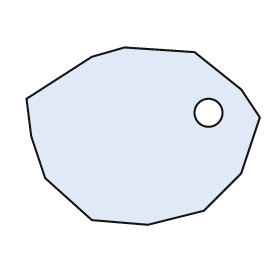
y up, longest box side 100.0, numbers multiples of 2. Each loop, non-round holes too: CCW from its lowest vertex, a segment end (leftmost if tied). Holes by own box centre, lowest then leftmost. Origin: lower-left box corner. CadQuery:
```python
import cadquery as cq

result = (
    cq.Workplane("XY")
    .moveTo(52.0, 0.0)
    .lineTo(76.0, 6.0)
    .lineTo(92.0, 22.0)
    .lineTo(100.0, 46.0)
    .lineTo(92.0, 58.0)
    .lineTo(72.0, 74.0)
    .lineTo(42.0, 76.0)
    .lineTo(28.0, 72.0)
    .lineTo(0.0, 54.0)
    .lineTo(2.0, 38.0)
    .lineTo(8.0, 20.0)
    .lineTo(28.0, 2.0)
    .close()
    .moveTo(78.0, 48.0)
    .circle(6.0)
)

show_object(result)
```